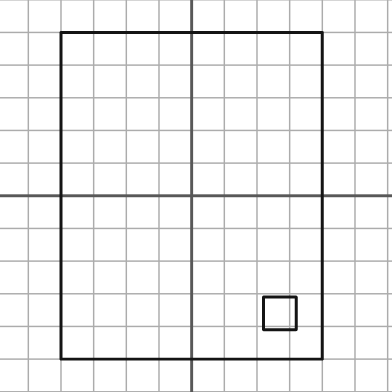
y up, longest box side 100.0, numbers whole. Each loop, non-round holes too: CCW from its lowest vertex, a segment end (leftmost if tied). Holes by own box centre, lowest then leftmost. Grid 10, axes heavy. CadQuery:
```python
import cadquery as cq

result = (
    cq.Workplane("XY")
    .moveTo(-40.0, -50.0)
    .lineTo(40.0, -50.0)
    .lineTo(40.0, 50.0)
    .lineTo(-40.0, 50.0)
    .close()
    .moveTo(22.0, -41.0)
    .lineTo(32.0, -41.0)
    .lineTo(32.0, -31.0)
    .lineTo(22.0, -31.0)
    .close()
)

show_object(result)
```